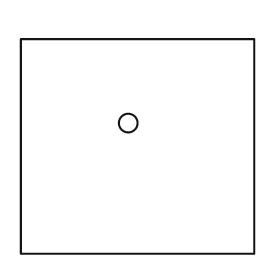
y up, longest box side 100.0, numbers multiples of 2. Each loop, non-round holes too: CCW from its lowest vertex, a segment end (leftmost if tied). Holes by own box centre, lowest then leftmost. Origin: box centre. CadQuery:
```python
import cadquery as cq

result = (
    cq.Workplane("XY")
    .moveTo(-50.0, -46.0)
    .lineTo(50.0, -46.0)
    .lineTo(50.0, 46.0)
    .lineTo(-50.0, 46.0)
    .close()
    .moveTo(-4.0, 10.0)
    .circle(4.0)
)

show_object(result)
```